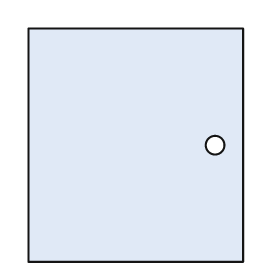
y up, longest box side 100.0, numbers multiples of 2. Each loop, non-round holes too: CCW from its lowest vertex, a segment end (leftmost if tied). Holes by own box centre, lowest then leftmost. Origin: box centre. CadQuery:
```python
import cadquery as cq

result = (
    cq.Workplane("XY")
    .moveTo(-46.0, -50.0)
    .lineTo(46.0, -50.0)
    .lineTo(46.0, 50.0)
    .lineTo(-46.0, 50.0)
    .close()
    .moveTo(34.0, 0.0)
    .circle(4.0)
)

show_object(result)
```